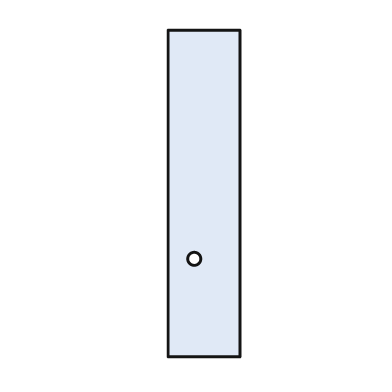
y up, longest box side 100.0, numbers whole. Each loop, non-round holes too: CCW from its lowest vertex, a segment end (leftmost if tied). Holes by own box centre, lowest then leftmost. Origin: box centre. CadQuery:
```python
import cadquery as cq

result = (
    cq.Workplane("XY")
    .moveTo(-11.0, -50.0)
    .lineTo(11.0, -50.0)
    .lineTo(11.0, 50.0)
    .lineTo(-11.0, 50.0)
    .close()
    .moveTo(-3.0, -20.0)
    .circle(2.0)
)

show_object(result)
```